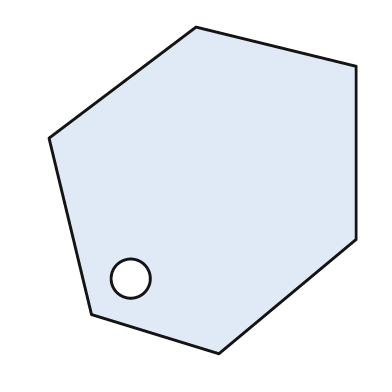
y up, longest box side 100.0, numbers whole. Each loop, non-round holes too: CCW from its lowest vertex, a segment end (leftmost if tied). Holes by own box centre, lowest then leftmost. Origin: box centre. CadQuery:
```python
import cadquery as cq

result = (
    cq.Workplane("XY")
    .moveTo(5.0, -50.0)
    .lineTo(47.0, -15.0)
    .lineTo(47.0, 38.0)
    .lineTo(-2.0, 50.0)
    .lineTo(-47.0, 16.0)
    .lineTo(-34.0, -38.0)
    .close()
    .moveTo(-22.0, -27.0)
    .circle(6.0)
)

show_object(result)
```